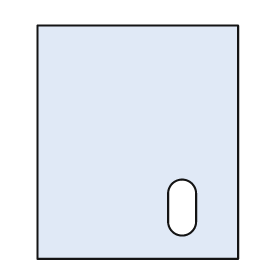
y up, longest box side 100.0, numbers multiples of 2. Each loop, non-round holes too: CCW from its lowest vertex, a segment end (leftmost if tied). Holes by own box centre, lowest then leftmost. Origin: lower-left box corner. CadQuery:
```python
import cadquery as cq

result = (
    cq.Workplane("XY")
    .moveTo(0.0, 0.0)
    .lineTo(86.0, 0.0)
    .lineTo(86.0, 100.0)
    .lineTo(0.0, 100.0)
    .close()
    .moveTo(56.0, 16.0)
    .threePointArc((62.0, 10.0), (68.0, 16.0))
    .lineTo(68.0, 28.0)
    .threePointArc((62.0, 34.0), (56.0, 28.0))
    .close()
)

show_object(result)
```